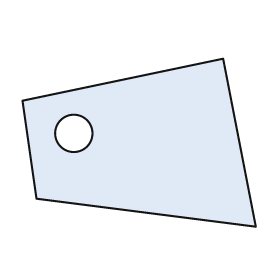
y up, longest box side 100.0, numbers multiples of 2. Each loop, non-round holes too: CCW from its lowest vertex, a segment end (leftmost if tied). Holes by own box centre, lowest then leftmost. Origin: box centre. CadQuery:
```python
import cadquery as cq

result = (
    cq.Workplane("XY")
    .moveTo(50.0, -36.0)
    .lineTo(36.0, 36.0)
    .lineTo(-50.0, 18.0)
    .lineTo(-44.0, -24.0)
    .close()
    .moveTo(-28.0, 4.0)
    .circle(8.0)
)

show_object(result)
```